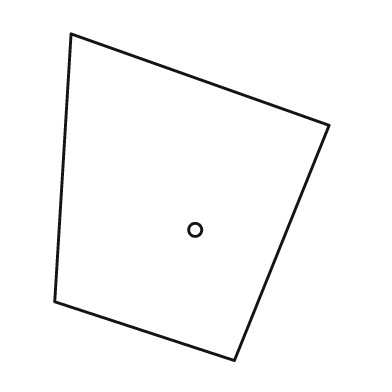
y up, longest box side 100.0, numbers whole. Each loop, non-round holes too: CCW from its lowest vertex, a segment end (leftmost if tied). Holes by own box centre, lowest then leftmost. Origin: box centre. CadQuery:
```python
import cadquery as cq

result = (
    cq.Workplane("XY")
    .moveTo(13.0, -50.0)
    .lineTo(42.0, 22.0)
    .lineTo(-37.0, 50.0)
    .lineTo(-42.0, -32.0)
    .close()
    .moveTo(1.0, -10.0)
    .circle(2.0)
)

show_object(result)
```